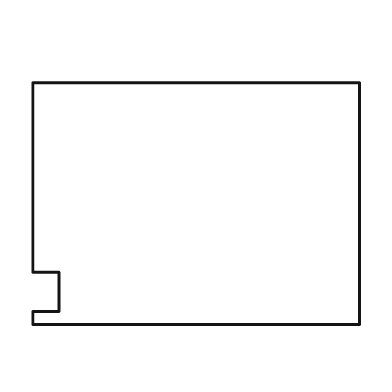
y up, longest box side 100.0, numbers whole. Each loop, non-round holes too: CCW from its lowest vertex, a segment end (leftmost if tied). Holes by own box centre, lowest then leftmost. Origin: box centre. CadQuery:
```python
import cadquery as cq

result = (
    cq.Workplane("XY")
    .moveTo(-50.0, -37.0)
    .lineTo(50.0, -37.0)
    .lineTo(50.0, 37.0)
    .lineTo(-50.0, 37.0)
    .lineTo(-50.0, -21.0)
    .lineTo(-42.0, -21.0)
    .lineTo(-42.0, -33.0)
    .lineTo(-50.0, -33.0)
    .close()
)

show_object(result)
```